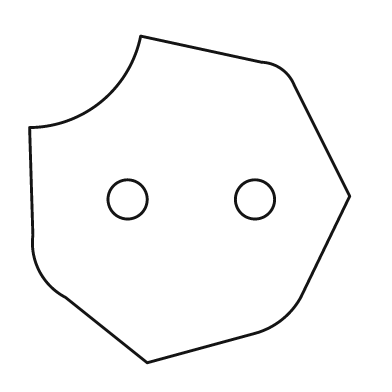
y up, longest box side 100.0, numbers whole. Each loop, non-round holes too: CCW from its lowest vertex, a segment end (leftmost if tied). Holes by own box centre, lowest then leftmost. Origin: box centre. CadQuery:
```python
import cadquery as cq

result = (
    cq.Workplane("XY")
    .moveTo(-13.0, -50.0)
    .lineTo(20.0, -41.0)
    .threePointArc((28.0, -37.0), (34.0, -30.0))
    .lineTo(49.0, 1.0)
    .lineTo(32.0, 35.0)
    .threePointArc((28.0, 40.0), (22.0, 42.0))
    .lineTo(-15.0, 50.0)
    .threePointArc((-27.0, 30.0), (-49.0, 22.0))
    .lineTo(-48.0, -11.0)
    .threePointArc((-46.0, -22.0), (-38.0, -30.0))
    .close()
    .moveTo(-19.0, 0.0)
    .circle(6.0)
    .moveTo(20.0, 0.0)
    .circle(6.0)
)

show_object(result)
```